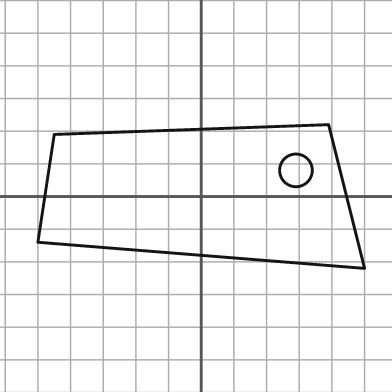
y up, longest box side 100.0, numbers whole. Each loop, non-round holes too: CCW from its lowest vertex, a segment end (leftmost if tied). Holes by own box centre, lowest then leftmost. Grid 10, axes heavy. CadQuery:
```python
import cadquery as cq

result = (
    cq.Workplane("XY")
    .moveTo(50.0, -22.0)
    .lineTo(39.0, 22.0)
    .lineTo(-45.0, 19.0)
    .lineTo(-50.0, -14.0)
    .close()
    .moveTo(29.0, 8.0)
    .circle(5.0)
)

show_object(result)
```